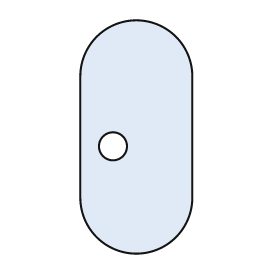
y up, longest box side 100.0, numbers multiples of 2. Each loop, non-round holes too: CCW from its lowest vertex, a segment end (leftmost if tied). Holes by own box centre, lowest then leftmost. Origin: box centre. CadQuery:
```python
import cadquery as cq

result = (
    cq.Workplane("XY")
    .moveTo(-24.0, -26.0)
    .threePointArc((0.0, -50.0), (24.0, -26.0))
    .lineTo(24.0, 26.0)
    .threePointArc((0.0, 50.0), (-24.0, 26.0))
    .close()
    .moveTo(-10.0, -4.0)
    .circle(6.0)
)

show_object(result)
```